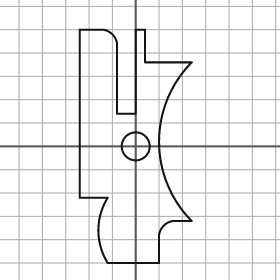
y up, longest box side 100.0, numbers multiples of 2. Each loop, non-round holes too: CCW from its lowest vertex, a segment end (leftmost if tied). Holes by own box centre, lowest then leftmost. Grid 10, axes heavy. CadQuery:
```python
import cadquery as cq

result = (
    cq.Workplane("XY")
    .moveTo(-12.0, -50.0)
    .lineTo(10.0, -50.0)
    .lineTo(10.0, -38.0)
    .threePointArc((12.0, -34.0), (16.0, -32.0))
    .lineTo(24.0, -32.0)
    .threePointArc((10.0, 2.0), (24.0, 36.0))
    .lineTo(4.0, 36.0)
    .lineTo(4.0, 50.0)
    .lineTo(0.0, 50.0)
    .lineTo(0.0, 14.0)
    .lineTo(-8.0, 14.0)
    .lineTo(-8.0, 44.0)
    .threePointArc((-10.0, 48.0), (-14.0, 50.0))
    .lineTo(-24.0, 50.0)
    .lineTo(-24.0, -22.0)
    .lineTo(-12.0, -22.0)
    .threePointArc((-16.0, -36.0), (-12.0, -50.0))
    .close()
    .moveTo(0.0, 0.0)
    .circle(6.0)
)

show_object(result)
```